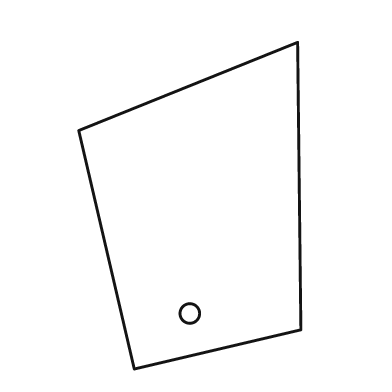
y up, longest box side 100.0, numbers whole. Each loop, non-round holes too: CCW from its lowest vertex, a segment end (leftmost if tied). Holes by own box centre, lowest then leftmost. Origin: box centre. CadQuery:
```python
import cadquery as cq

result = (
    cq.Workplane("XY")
    .moveTo(-17.0, -50.0)
    .lineTo(34.0, -38.0)
    .lineTo(33.0, 50.0)
    .lineTo(-34.0, 23.0)
    .close()
    .moveTo(0.0, -33.0)
    .circle(3.0)
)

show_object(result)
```